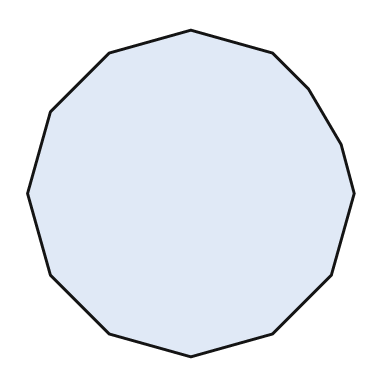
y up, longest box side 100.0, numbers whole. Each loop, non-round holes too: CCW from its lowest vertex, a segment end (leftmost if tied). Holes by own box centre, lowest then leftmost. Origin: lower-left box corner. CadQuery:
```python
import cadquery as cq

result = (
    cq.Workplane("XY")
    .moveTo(50.0, 0.0)
    .lineTo(75.0, 7.0)
    .lineTo(93.0, 25.0)
    .lineTo(100.0, 50.0)
    .lineTo(96.0, 65.0)
    .lineTo(86.0, 82.0)
    .lineTo(75.0, 93.0)
    .lineTo(50.0, 100.0)
    .lineTo(25.0, 93.0)
    .lineTo(7.0, 75.0)
    .lineTo(0.0, 50.0)
    .lineTo(7.0, 25.0)
    .lineTo(25.0, 7.0)
    .close()
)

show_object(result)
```